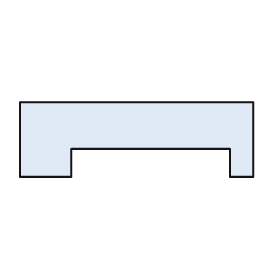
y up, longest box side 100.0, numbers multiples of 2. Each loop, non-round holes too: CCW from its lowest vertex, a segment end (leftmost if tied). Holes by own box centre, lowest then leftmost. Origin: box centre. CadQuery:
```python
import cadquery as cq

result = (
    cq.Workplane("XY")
    .moveTo(-50.0, -16.0)
    .lineTo(-28.0, -16.0)
    .lineTo(-28.0, -4.0)
    .lineTo(40.0, -4.0)
    .lineTo(40.0, -16.0)
    .lineTo(50.0, -16.0)
    .lineTo(50.0, 16.0)
    .lineTo(-50.0, 16.0)
    .close()
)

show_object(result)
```